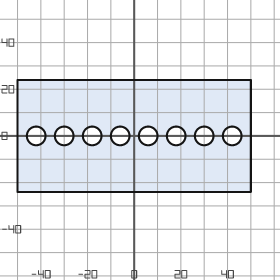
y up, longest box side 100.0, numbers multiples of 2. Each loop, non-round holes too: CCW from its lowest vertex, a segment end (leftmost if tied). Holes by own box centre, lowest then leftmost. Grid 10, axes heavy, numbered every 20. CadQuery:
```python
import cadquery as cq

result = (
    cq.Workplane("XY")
    .moveTo(-50.0, -24.0)
    .lineTo(50.0, -24.0)
    .lineTo(50.0, 24.0)
    .lineTo(-50.0, 24.0)
    .close()
    .moveTo(-42.0, 0.0)
    .circle(4.0)
    .moveTo(-30.0, 0.0)
    .circle(4.0)
    .moveTo(-18.0, 0.0)
    .circle(4.0)
    .moveTo(-6.0, 0.0)
    .circle(4.0)
    .moveTo(6.0, 0.0)
    .circle(4.0)
    .moveTo(18.0, 0.0)
    .circle(4.0)
    .moveTo(30.0, 0.0)
    .circle(4.0)
    .moveTo(42.0, 0.0)
    .circle(4.0)
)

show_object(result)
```